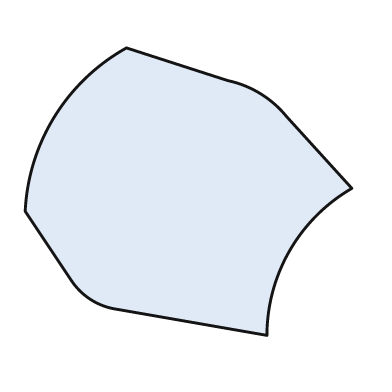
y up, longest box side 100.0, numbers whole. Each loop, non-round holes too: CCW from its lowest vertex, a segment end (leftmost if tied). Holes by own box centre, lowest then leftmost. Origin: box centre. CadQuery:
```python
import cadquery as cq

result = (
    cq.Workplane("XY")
    .moveTo(24.0, -44.0)
    .threePointArc((31.0, -18.0), (50.0, 1.0))
    .lineTo(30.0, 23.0)
    .threePointArc((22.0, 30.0), (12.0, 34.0))
    .lineTo(-19.0, 44.0)
    .threePointArc((-41.0, 23.0), (-50.0, -6.0))
    .lineTo(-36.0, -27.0)
    .threePointArc((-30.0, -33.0), (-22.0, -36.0))
    .close()
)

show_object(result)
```